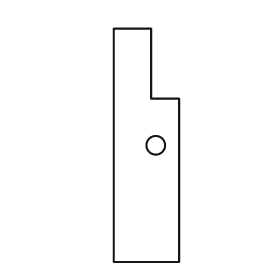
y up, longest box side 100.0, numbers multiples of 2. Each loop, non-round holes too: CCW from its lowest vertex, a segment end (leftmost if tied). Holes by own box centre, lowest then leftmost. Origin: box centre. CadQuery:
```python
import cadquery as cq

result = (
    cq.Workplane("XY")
    .moveTo(-14.0, -50.0)
    .lineTo(14.0, -50.0)
    .lineTo(14.0, 20.0)
    .lineTo(2.0, 20.0)
    .lineTo(2.0, 50.0)
    .lineTo(-14.0, 50.0)
    .close()
    .moveTo(4.0, 0.0)
    .circle(4.0)
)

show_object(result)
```